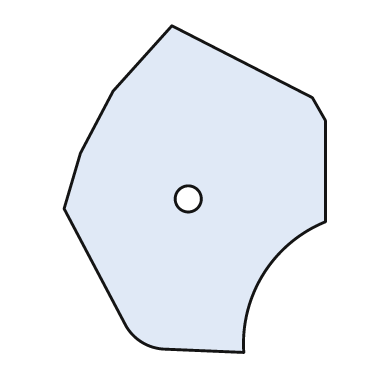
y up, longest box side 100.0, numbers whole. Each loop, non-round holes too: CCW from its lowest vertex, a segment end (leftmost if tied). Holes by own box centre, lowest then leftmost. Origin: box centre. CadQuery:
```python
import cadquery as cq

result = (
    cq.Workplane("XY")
    .moveTo(15.0, -50.0)
    .threePointArc((21.0, -26.0), (40.0, -10.0))
    .lineTo(40.0, 21.0)
    .lineTo(36.0, 28.0)
    .lineTo(-7.0, 50.0)
    .lineTo(-25.0, 30.0)
    .lineTo(-35.0, 11.0)
    .lineTo(-40.0, -6.0)
    .lineTo(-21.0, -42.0)
    .threePointArc((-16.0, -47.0), (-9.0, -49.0))
    .close()
    .moveTo(-2.0, -3.0)
    .circle(4.0)
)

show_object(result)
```